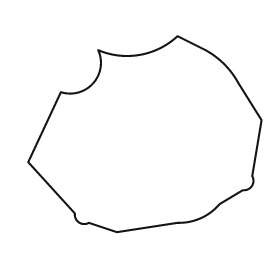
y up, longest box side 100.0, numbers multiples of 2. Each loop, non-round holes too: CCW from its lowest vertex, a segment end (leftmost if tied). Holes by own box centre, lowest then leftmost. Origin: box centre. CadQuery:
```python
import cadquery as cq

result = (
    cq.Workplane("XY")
    .moveTo(-12.0, -42.0)
    .lineTo(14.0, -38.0)
    .threePointArc((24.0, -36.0), (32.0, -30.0))
    .lineTo(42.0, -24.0)
    .threePointArc((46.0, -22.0), (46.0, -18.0))
    .lineTo(50.0, 6.0)
    .lineTo(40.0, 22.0)
    .threePointArc((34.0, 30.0), (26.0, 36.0))
    .lineTo(14.0, 42.0)
    .threePointArc((-2.0, 34.0), (-20.0, 36.0))
    .threePointArc((-22.0, 22.0), (-36.0, 18.0))
    .lineTo(-50.0, -12.0)
    .lineTo(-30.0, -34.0)
    .threePointArc((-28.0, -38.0), (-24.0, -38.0))
    .close()
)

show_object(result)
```